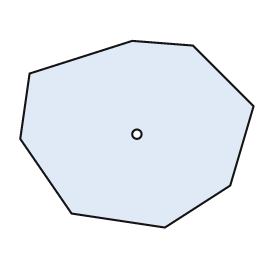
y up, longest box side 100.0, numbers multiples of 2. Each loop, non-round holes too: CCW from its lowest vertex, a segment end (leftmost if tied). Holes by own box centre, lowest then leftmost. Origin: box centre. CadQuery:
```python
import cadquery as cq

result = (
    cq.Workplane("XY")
    .moveTo(12.0, -40.0)
    .lineTo(40.0, -22.0)
    .lineTo(50.0, 12.0)
    .lineTo(24.0, 38.0)
    .lineTo(-2.0, 40.0)
    .lineTo(-46.0, 26.0)
    .lineTo(-50.0, -2.0)
    .lineTo(-28.0, -34.0)
    .close()
    .moveTo(0.0, 0.0)
    .circle(2.0)
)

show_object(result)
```